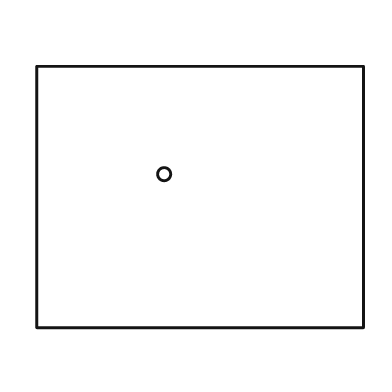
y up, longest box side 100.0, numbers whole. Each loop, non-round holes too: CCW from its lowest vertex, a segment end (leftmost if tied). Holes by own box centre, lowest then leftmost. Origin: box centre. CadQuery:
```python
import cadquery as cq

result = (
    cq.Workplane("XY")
    .moveTo(-50.0, -40.0)
    .lineTo(50.0, -40.0)
    .lineTo(50.0, 40.0)
    .lineTo(-50.0, 40.0)
    .close()
    .moveTo(-11.0, 7.0)
    .circle(2.0)
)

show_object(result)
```